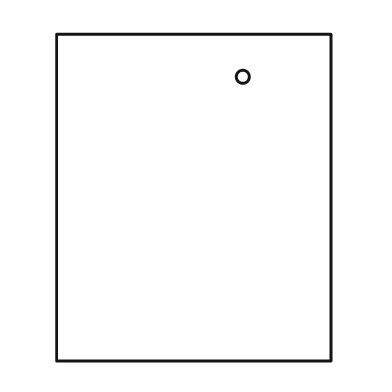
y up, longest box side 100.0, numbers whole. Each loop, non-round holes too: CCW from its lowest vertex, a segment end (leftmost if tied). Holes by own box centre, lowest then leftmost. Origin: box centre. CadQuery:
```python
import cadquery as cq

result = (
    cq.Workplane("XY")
    .moveTo(-42.0, -50.0)
    .lineTo(42.0, -50.0)
    .lineTo(42.0, 50.0)
    .lineTo(-42.0, 50.0)
    .close()
    .moveTo(15.0, 37.0)
    .circle(2.0)
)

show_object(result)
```